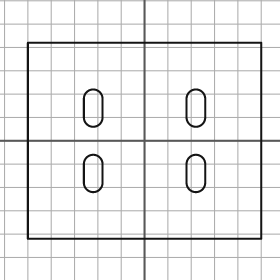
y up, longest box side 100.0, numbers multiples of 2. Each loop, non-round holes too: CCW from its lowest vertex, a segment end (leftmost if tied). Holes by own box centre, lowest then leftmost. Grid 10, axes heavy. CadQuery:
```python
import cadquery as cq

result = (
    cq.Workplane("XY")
    .moveTo(-50.0, -42.0)
    .lineTo(50.0, -42.0)
    .lineTo(50.0, 42.0)
    .lineTo(-50.0, 42.0)
    .close()
    .moveTo(-26.0, -18.0)
    .threePointArc((-22.0, -22.0), (-18.0, -18.0))
    .lineTo(-18.0, -10.0)
    .threePointArc((-22.0, -6.0), (-26.0, -10.0))
    .close()
    .moveTo(18.0, -18.0)
    .threePointArc((22.0, -22.0), (26.0, -18.0))
    .lineTo(26.0, -10.0)
    .threePointArc((22.0, -6.0), (18.0, -10.0))
    .close()
    .moveTo(-26.0, 10.0)
    .threePointArc((-22.0, 6.0), (-18.0, 10.0))
    .lineTo(-18.0, 18.0)
    .threePointArc((-22.0, 22.0), (-26.0, 18.0))
    .close()
    .moveTo(18.0, 10.0)
    .threePointArc((22.0, 6.0), (26.0, 10.0))
    .lineTo(26.0, 18.0)
    .threePointArc((22.0, 22.0), (18.0, 18.0))
    .close()
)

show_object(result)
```